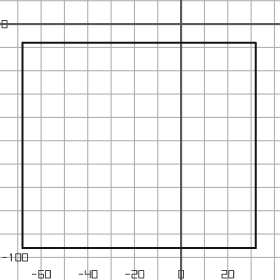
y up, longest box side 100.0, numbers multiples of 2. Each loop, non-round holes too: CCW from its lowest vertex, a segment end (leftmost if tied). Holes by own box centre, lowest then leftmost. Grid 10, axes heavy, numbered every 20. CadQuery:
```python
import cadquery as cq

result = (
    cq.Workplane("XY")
    .moveTo(-68.0, -96.0)
    .lineTo(32.0, -96.0)
    .lineTo(32.0, -8.0)
    .lineTo(-68.0, -8.0)
    .close()
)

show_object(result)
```